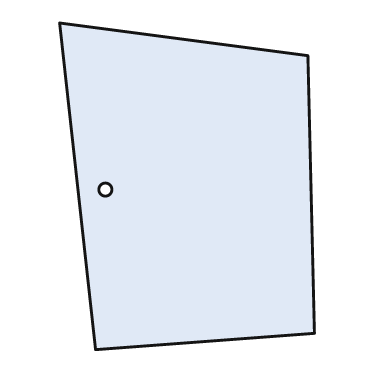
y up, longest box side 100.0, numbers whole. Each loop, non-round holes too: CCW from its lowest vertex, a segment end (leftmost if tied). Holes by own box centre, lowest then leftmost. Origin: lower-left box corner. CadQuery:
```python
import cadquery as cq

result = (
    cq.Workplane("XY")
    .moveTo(11.0, 0.0)
    .lineTo(78.0, 5.0)
    .lineTo(76.0, 90.0)
    .lineTo(0.0, 100.0)
    .close()
    .moveTo(14.0, 49.0)
    .circle(2.0)
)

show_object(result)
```